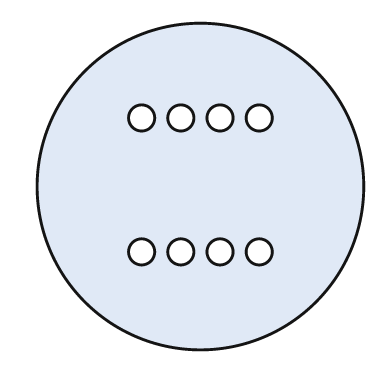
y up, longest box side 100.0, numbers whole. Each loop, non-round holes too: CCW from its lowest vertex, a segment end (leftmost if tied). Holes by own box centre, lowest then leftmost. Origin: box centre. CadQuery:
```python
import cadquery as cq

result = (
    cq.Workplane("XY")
    .moveTo(0.0, 0.0)
    .circle(50.0)
    .moveTo(-18.0, -20.0)
    .circle(4.0)
    .moveTo(-6.0, -20.0)
    .circle(4.0)
    .moveTo(6.0, -20.0)
    .circle(4.0)
    .moveTo(18.0, -20.0)
    .circle(4.0)
    .moveTo(-18.0, 21.0)
    .circle(4.0)
    .moveTo(-6.0, 21.0)
    .circle(4.0)
    .moveTo(6.0, 21.0)
    .circle(4.0)
    .moveTo(18.0, 21.0)
    .circle(4.0)
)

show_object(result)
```